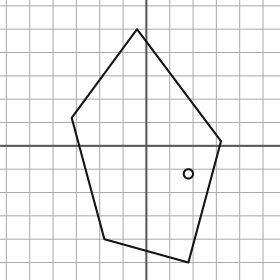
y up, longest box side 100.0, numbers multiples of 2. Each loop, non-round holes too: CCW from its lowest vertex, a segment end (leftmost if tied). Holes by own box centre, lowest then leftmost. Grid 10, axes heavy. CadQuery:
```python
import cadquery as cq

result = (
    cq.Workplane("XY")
    .moveTo(18.0, -50.0)
    .lineTo(32.0, 2.0)
    .lineTo(-4.0, 50.0)
    .lineTo(-32.0, 12.0)
    .lineTo(-18.0, -40.0)
    .close()
    .moveTo(18.0, -12.0)
    .circle(2.0)
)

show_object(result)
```